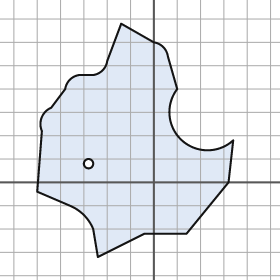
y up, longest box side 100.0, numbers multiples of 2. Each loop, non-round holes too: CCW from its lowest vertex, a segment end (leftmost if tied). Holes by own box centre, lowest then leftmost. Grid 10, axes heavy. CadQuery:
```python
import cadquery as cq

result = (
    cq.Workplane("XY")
    .moveTo(-24.0, -32.0)
    .lineTo(-4.0, -22.0)
    .lineTo(14.0, -22.0)
    .lineTo(32.0, 0.0)
    .lineTo(34.0, 18.0)
    .threePointArc((12.0, 18.0), (10.0, 40.0))
    .lineTo(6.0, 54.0)
    .threePointArc((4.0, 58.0), (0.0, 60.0))
    .lineTo(-14.0, 68.0)
    .lineTo(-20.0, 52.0)
    .threePointArc((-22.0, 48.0), (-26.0, 46.0))
    .lineTo(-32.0, 46.0)
    .threePointArc((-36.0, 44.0), (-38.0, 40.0))
    .lineTo(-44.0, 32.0)
    .threePointArc((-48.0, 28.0), (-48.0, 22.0))
    .lineTo(-50.0, -4.0)
    .lineTo(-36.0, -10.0)
    .threePointArc((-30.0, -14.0), (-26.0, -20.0))
    .close()
    .moveTo(-28.0, 8.0)
    .circle(2.0)
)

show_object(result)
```